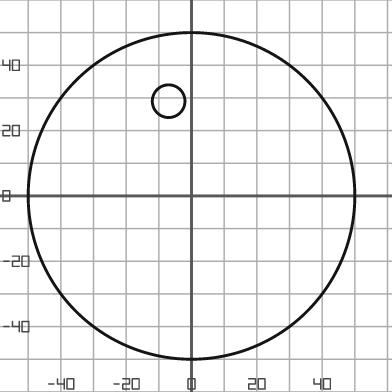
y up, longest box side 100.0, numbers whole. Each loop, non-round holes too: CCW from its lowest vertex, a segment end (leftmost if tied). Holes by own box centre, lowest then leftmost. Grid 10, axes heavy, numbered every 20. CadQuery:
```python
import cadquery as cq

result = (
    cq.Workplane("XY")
    .moveTo(0.0, 0.0)
    .circle(50.0)
    .moveTo(-7.0, 29.0)
    .circle(5.0)
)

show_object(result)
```